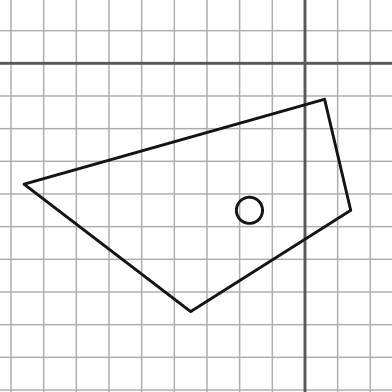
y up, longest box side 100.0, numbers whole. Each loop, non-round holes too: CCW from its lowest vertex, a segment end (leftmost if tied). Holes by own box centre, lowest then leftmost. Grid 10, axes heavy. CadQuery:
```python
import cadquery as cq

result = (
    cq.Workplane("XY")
    .moveTo(-35.0, -76.0)
    .lineTo(14.0, -45.0)
    .lineTo(6.0, -11.0)
    .lineTo(-86.0, -37.0)
    .close()
    .moveTo(-17.0, -45.0)
    .circle(4.0)
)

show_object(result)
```